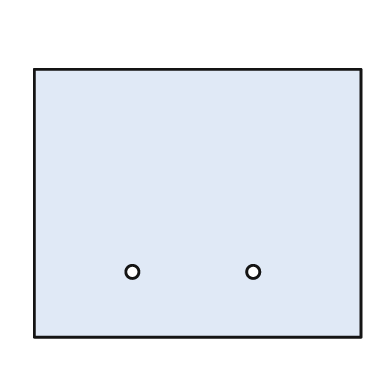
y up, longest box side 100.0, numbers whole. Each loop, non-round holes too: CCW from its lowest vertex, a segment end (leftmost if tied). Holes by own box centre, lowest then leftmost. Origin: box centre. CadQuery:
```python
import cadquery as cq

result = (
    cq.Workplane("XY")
    .moveTo(-50.0, -41.0)
    .lineTo(50.0, -41.0)
    .lineTo(50.0, 41.0)
    .lineTo(-50.0, 41.0)
    .close()
    .moveTo(-20.0, -21.0)
    .circle(2.0)
    .moveTo(17.0, -21.0)
    .circle(2.0)
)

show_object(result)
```